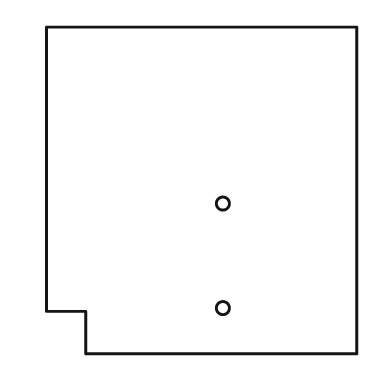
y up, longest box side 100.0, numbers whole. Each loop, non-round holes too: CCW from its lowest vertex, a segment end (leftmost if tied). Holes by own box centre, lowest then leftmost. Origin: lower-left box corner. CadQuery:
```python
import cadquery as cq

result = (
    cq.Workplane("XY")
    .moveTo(12.0, 0.0)
    .lineTo(95.0, 0.0)
    .lineTo(95.0, 100.0)
    .lineTo(0.0, 100.0)
    .lineTo(0.0, 13.0)
    .lineTo(12.0, 13.0)
    .close()
    .moveTo(54.0, 14.0)
    .circle(2.0)
    .moveTo(54.0, 46.0)
    .circle(2.0)
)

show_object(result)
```